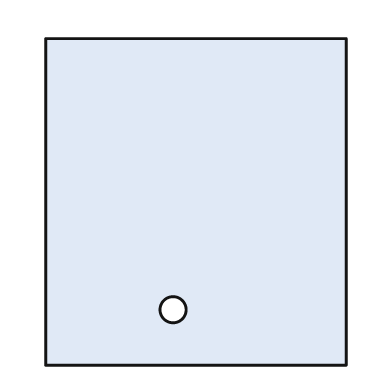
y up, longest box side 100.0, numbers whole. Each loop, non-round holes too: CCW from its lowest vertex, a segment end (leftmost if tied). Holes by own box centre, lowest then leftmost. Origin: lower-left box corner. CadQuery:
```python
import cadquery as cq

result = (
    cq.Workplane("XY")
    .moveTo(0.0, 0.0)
    .lineTo(92.0, 0.0)
    .lineTo(92.0, 100.0)
    .lineTo(0.0, 100.0)
    .close()
    .moveTo(39.0, 17.0)
    .circle(4.0)
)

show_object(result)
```